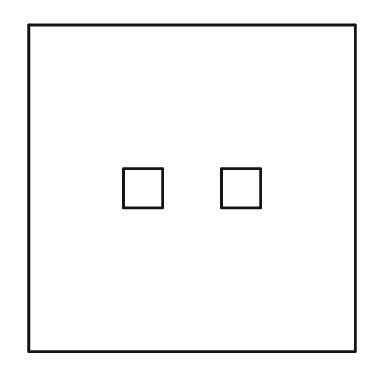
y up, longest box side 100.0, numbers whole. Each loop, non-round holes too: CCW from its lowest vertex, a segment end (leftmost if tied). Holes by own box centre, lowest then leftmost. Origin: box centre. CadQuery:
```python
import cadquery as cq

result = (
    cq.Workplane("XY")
    .moveTo(-50.0, -50.0)
    .lineTo(50.0, -50.0)
    .lineTo(50.0, 50.0)
    .lineTo(-50.0, 50.0)
    .close()
    .moveTo(-21.0, -6.0)
    .lineTo(-9.0, -6.0)
    .lineTo(-9.0, 6.0)
    .lineTo(-21.0, 6.0)
    .close()
    .moveTo(9.0, -6.0)
    .lineTo(21.0, -6.0)
    .lineTo(21.0, 6.0)
    .lineTo(9.0, 6.0)
    .close()
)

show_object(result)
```